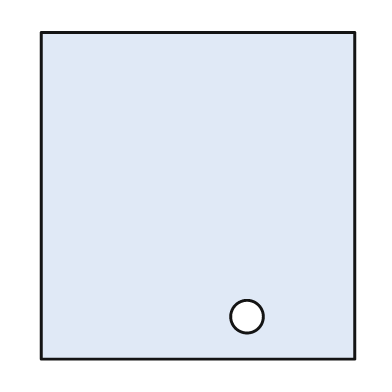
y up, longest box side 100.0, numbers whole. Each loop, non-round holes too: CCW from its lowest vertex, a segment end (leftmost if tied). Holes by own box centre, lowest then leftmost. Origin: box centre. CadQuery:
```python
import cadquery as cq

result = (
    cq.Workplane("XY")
    .moveTo(-48.0, -50.0)
    .lineTo(48.0, -50.0)
    .lineTo(48.0, 50.0)
    .lineTo(-48.0, 50.0)
    .close()
    .moveTo(15.0, -37.0)
    .circle(5.0)
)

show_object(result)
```